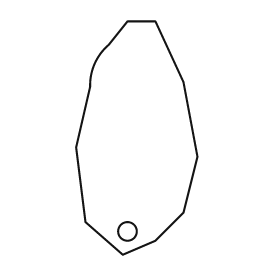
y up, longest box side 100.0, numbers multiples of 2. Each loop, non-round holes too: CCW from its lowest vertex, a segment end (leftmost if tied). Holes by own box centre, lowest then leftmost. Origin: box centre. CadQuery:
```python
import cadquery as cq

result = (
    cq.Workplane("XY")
    .moveTo(-6.0, -50.0)
    .lineTo(8.0, -44.0)
    .lineTo(20.0, -32.0)
    .lineTo(26.0, -8.0)
    .lineTo(20.0, 24.0)
    .lineTo(8.0, 50.0)
    .lineTo(-4.0, 50.0)
    .lineTo(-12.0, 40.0)
    .threePointArc((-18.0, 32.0), (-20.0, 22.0))
    .lineTo(-26.0, -4.0)
    .lineTo(-22.0, -36.0)
    .close()
    .moveTo(-4.0, -40.0)
    .circle(4.0)
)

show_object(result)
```